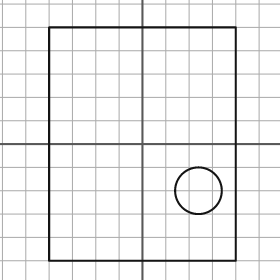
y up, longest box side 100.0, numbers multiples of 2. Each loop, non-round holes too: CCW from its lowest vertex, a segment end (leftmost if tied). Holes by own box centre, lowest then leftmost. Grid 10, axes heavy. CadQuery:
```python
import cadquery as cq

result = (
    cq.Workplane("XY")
    .moveTo(-40.0, -50.0)
    .lineTo(40.0, -50.0)
    .lineTo(40.0, 50.0)
    .lineTo(-40.0, 50.0)
    .close()
    .moveTo(24.0, -20.0)
    .circle(10.0)
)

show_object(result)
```